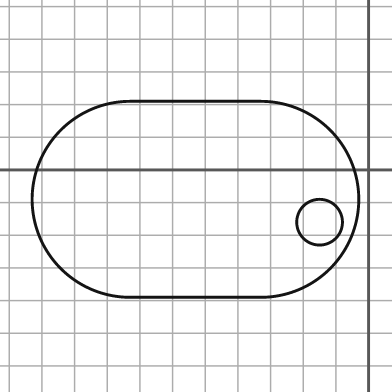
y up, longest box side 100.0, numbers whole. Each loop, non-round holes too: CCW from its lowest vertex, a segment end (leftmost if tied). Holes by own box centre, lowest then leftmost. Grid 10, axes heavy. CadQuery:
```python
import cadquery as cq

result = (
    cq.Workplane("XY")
    .moveTo(-73.0, -39.0)
    .lineTo(-33.0, -39.0)
    .threePointArc((-3.0, -9.0), (-33.0, 21.0))
    .lineTo(-73.0, 21.0)
    .threePointArc((-103.0, -9.0), (-73.0, -39.0))
    .close()
    .moveTo(-15.0, -16.0)
    .circle(7.0)
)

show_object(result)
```